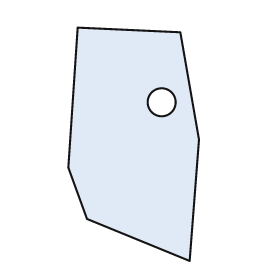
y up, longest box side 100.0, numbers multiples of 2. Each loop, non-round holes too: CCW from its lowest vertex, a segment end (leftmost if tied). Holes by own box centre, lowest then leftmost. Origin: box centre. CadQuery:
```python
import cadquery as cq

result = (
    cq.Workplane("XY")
    .moveTo(24.0, -50.0)
    .lineTo(28.0, 2.0)
    .lineTo(20.0, 48.0)
    .lineTo(-24.0, 50.0)
    .lineTo(-28.0, -10.0)
    .lineTo(-20.0, -32.0)
    .close()
    .moveTo(12.0, 18.0)
    .circle(6.0)
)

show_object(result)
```